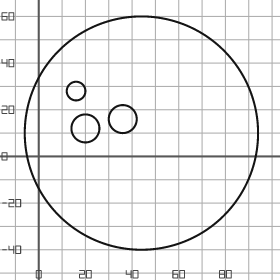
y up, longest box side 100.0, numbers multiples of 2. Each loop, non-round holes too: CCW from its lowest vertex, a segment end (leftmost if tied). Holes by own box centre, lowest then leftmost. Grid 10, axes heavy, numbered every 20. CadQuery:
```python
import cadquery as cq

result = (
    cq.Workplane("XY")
    .moveTo(44.0, 10.0)
    .circle(50.0)
    .moveTo(20.0, 12.0)
    .circle(6.0)
    .moveTo(36.0, 16.0)
    .circle(6.0)
    .moveTo(16.0, 28.0)
    .circle(4.0)
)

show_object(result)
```